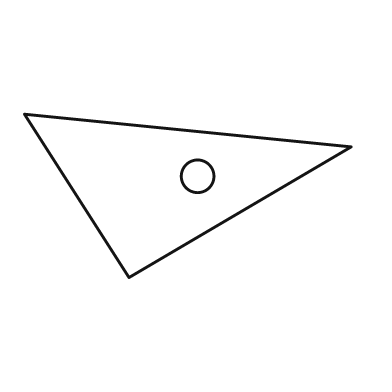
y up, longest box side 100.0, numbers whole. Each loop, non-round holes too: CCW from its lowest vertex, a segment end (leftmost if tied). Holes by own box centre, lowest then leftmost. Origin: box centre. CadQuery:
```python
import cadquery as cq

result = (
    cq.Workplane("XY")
    .moveTo(-18.0, -25.0)
    .lineTo(50.0, 15.0)
    .lineTo(-50.0, 25.0)
    .close()
    .moveTo(3.0, 6.0)
    .circle(5.0)
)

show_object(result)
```